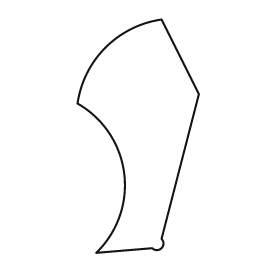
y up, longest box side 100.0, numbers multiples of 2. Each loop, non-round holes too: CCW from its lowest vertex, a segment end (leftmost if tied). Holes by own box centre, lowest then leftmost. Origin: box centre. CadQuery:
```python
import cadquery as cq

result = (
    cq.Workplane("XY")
    .moveTo(-18.0, -50.0)
    .lineTo(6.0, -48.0)
    .threePointArc((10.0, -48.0), (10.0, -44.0))
    .lineTo(26.0, 18.0)
    .lineTo(10.0, 50.0)
    .threePointArc((-14.0, 38.0), (-26.0, 14.0))
    .threePointArc((-6.0, -16.0), (-18.0, -50.0))
    .close()
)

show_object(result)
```